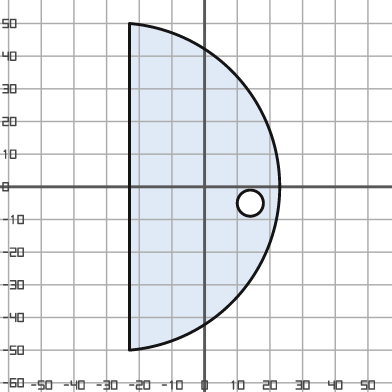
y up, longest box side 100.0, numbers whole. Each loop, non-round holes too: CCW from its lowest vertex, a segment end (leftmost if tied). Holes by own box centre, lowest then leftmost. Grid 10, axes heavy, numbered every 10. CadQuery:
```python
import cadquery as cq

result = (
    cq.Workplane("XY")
    .moveTo(-23.0, -50.0)
    .threePointArc((23.0, 0.0), (-23.0, 50.0))
    .close()
    .moveTo(14.0, -5.0)
    .circle(4.0)
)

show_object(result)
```